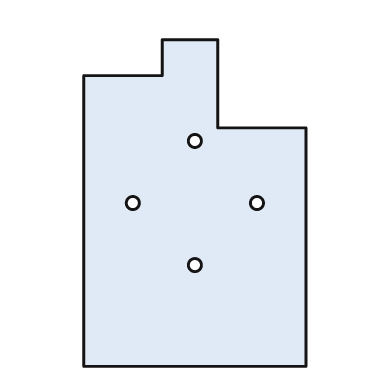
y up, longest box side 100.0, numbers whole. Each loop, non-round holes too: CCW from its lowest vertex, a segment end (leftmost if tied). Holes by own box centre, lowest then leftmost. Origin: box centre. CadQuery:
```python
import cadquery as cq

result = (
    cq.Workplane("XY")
    .moveTo(-34.0, -50.0)
    .lineTo(34.0, -50.0)
    .lineTo(34.0, 23.0)
    .lineTo(7.0, 23.0)
    .lineTo(7.0, 50.0)
    .lineTo(-10.0, 50.0)
    .lineTo(-10.0, 39.0)
    .lineTo(-34.0, 39.0)
    .close()
    .moveTo(0.0, -19.0)
    .circle(2.0)
    .moveTo(-19.0, 0.0)
    .circle(2.0)
    .moveTo(19.0, 0.0)
    .circle(2.0)
    .moveTo(0.0, 19.0)
    .circle(2.0)
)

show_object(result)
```